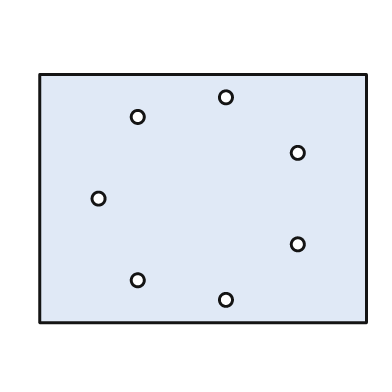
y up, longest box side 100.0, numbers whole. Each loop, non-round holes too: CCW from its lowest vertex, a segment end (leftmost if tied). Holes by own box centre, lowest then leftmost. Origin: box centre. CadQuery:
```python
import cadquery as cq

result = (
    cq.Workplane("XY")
    .moveTo(-50.0, -38.0)
    .lineTo(50.0, -38.0)
    .lineTo(50.0, 38.0)
    .lineTo(-50.0, 38.0)
    .close()
    .moveTo(7.0, -31.0)
    .circle(2.0)
    .moveTo(-20.0, -25.0)
    .circle(2.0)
    .moveTo(29.0, -14.0)
    .circle(2.0)
    .moveTo(-32.0, 0.0)
    .circle(2.0)
    .moveTo(29.0, 14.0)
    .circle(2.0)
    .moveTo(-20.0, 25.0)
    .circle(2.0)
    .moveTo(7.0, 31.0)
    .circle(2.0)
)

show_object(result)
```